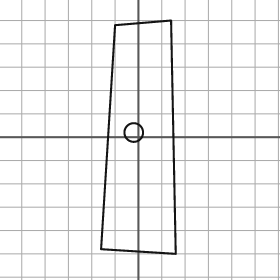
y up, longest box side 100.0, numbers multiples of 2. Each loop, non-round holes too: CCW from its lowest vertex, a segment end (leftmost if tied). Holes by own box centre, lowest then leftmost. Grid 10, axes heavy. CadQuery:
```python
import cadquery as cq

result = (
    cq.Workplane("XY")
    .moveTo(16.0, -50.0)
    .lineTo(14.0, 50.0)
    .lineTo(-10.0, 48.0)
    .lineTo(-16.0, -48.0)
    .close()
    .moveTo(-2.0, 2.0)
    .circle(4.0)
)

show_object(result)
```